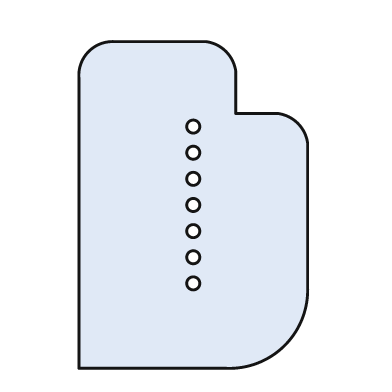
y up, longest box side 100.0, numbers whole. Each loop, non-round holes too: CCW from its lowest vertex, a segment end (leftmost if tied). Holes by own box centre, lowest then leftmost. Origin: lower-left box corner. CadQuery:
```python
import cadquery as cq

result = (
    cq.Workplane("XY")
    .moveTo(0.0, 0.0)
    .lineTo(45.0, 0.0)
    .threePointArc((63.0, 7.0), (70.0, 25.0))
    .lineTo(70.0, 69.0)
    .threePointArc((67.0, 75.0), (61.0, 78.0))
    .lineTo(48.0, 78.0)
    .lineTo(48.0, 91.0)
    .threePointArc((45.0, 97.0), (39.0, 100.0))
    .lineTo(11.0, 100.0)
    .threePointArc((3.0, 97.0), (0.0, 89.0))
    .close()
    .moveTo(35.0, 26.0)
    .circle(2.0)
    .moveTo(35.0, 34.0)
    .circle(2.0)
    .moveTo(35.0, 42.0)
    .circle(2.0)
    .moveTo(35.0, 50.0)
    .circle(2.0)
    .moveTo(35.0, 58.0)
    .circle(2.0)
    .moveTo(35.0, 66.0)
    .circle(2.0)
    .moveTo(35.0, 74.0)
    .circle(2.0)
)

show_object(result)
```